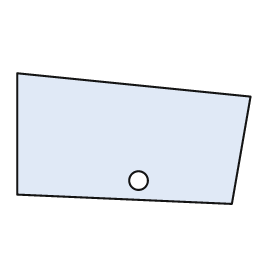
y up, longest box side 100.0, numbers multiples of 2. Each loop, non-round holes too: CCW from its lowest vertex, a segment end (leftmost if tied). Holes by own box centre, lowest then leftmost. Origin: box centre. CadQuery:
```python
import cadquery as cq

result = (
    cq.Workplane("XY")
    .moveTo(42.0, -28.0)
    .lineTo(50.0, 18.0)
    .lineTo(-50.0, 28.0)
    .lineTo(-50.0, -24.0)
    .close()
    .moveTo(2.0, -18.0)
    .circle(4.0)
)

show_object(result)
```